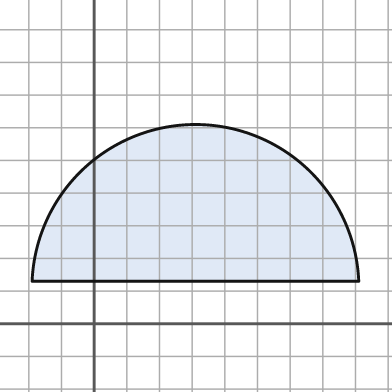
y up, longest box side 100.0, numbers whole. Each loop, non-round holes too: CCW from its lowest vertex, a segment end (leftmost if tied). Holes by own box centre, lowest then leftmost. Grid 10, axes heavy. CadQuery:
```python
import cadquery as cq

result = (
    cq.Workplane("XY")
    .moveTo(-19.0, 13.0)
    .lineTo(81.0, 13.0)
    .threePointArc((31.0, 61.0), (-19.0, 13.0))
    .close()
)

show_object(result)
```